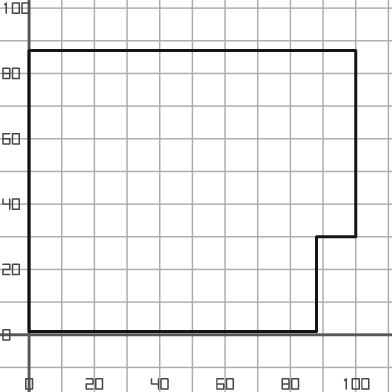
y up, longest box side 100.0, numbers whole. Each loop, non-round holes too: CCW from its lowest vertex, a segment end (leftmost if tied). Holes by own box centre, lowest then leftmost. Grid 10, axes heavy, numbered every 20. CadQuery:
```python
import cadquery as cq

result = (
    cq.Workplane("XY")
    .moveTo(0.0, 1.0)
    .lineTo(88.0, 1.0)
    .lineTo(88.0, 30.0)
    .lineTo(100.0, 30.0)
    .lineTo(100.0, 87.0)
    .lineTo(0.0, 87.0)
    .close()
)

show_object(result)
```